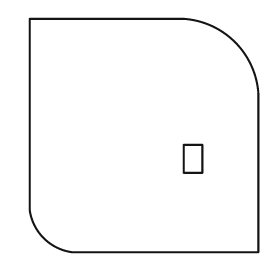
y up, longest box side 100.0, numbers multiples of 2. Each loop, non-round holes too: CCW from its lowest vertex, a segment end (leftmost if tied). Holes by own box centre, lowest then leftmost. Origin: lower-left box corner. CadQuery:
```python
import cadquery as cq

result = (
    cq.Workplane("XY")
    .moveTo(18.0, 0.0)
    .lineTo(98.0, 0.0)
    .lineTo(98.0, 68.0)
    .threePointArc((88.0, 90.0), (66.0, 100.0))
    .lineTo(0.0, 100.0)
    .lineTo(0.0, 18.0)
    .threePointArc((6.0, 6.0), (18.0, 0.0))
    .close()
    .moveTo(66.0, 34.0)
    .lineTo(74.0, 34.0)
    .lineTo(74.0, 46.0)
    .lineTo(66.0, 46.0)
    .close()
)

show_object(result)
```